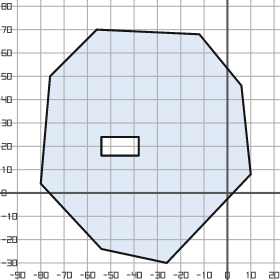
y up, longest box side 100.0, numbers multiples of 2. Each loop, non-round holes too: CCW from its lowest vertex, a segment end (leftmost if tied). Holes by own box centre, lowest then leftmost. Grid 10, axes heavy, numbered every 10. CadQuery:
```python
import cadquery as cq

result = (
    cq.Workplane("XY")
    .moveTo(-26.0, -30.0)
    .lineTo(10.0, 8.0)
    .lineTo(6.0, 46.0)
    .lineTo(-12.0, 68.0)
    .lineTo(-56.0, 70.0)
    .lineTo(-76.0, 50.0)
    .lineTo(-80.0, 4.0)
    .lineTo(-54.0, -24.0)
    .close()
    .moveTo(-54.0, 16.0)
    .lineTo(-38.0, 16.0)
    .lineTo(-38.0, 24.0)
    .lineTo(-54.0, 24.0)
    .close()
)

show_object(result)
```